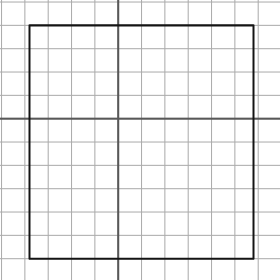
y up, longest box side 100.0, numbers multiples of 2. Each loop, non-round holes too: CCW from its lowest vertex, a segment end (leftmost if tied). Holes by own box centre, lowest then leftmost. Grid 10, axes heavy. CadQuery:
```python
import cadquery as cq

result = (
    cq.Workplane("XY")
    .moveTo(-38.0, -60.0)
    .lineTo(58.0, -60.0)
    .lineTo(58.0, 40.0)
    .lineTo(-38.0, 40.0)
    .close()
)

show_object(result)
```